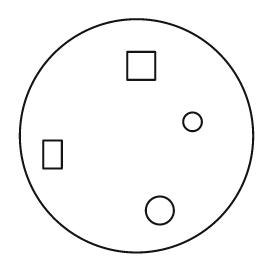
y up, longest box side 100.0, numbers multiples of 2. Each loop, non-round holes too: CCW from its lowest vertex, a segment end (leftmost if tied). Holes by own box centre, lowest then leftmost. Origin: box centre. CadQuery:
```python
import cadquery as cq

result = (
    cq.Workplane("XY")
    .moveTo(0.0, 0.0)
    .circle(50.0)
    .moveTo(10.0, -32.0)
    .circle(6.0)
    .moveTo(-40.0, -14.0)
    .lineTo(-32.0, -14.0)
    .lineTo(-32.0, -2.0)
    .lineTo(-40.0, -2.0)
    .close()
    .moveTo(24.0, 6.0)
    .circle(4.0)
    .moveTo(-4.0, 24.0)
    .lineTo(8.0, 24.0)
    .lineTo(8.0, 36.0)
    .lineTo(-4.0, 36.0)
    .close()
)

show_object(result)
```